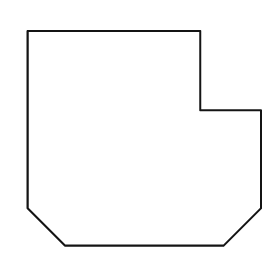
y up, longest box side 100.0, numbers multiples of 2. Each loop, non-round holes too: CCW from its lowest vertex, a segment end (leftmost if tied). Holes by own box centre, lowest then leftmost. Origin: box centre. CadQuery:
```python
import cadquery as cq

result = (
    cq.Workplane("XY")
    .moveTo(-34.0, -46.0)
    .lineTo(34.0, -46.0)
    .lineTo(50.0, -30.0)
    .lineTo(50.0, 12.0)
    .lineTo(24.0, 12.0)
    .lineTo(24.0, 46.0)
    .lineTo(-50.0, 46.0)
    .lineTo(-50.0, -30.0)
    .close()
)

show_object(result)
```